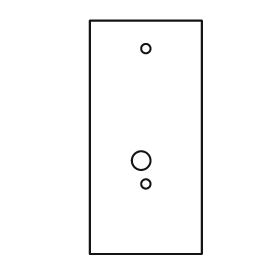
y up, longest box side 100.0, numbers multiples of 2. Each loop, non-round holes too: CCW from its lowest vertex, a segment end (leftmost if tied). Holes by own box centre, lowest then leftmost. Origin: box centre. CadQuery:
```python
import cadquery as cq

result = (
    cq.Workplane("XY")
    .moveTo(-24.0, -50.0)
    .lineTo(24.0, -50.0)
    .lineTo(24.0, 50.0)
    .lineTo(-24.0, 50.0)
    .close()
    .moveTo(0.0, -20.0)
    .circle(2.0)
    .moveTo(-2.0, -10.0)
    .circle(4.0)
    .moveTo(0.0, 38.0)
    .circle(2.0)
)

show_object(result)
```